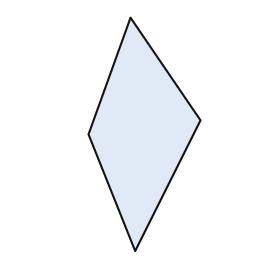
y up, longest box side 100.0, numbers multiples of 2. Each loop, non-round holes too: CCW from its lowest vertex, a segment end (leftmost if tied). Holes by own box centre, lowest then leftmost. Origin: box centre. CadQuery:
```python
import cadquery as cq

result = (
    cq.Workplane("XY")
    .moveTo(-4.0, -50.0)
    .lineTo(24.0, 6.0)
    .lineTo(-6.0, 50.0)
    .lineTo(-24.0, 0.0)
    .close()
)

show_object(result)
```